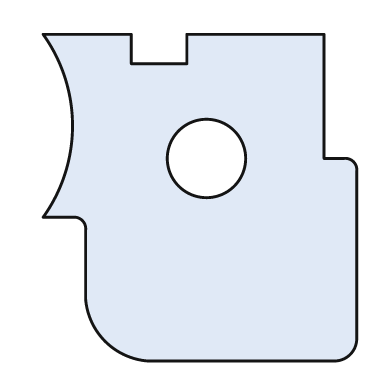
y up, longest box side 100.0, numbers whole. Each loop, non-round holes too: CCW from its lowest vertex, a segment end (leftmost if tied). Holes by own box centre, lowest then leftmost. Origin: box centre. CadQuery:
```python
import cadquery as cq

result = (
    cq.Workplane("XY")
    .moveTo(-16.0, -50.0)
    .lineTo(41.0, -50.0)
    .threePointArc((46.0, -48.0), (48.0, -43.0))
    .lineTo(48.0, 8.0)
    .threePointArc((47.0, 11.0), (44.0, 12.0))
    .lineTo(38.0, 12.0)
    .lineTo(38.0, 50.0)
    .lineTo(-4.0, 50.0)
    .lineTo(-4.0, 41.0)
    .lineTo(-21.0, 41.0)
    .lineTo(-21.0, 50.0)
    .lineTo(-48.0, 50.0)
    .threePointArc((-39.0, 22.0), (-48.0, -6.0))
    .lineTo(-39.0, -6.0)
    .threePointArc((-36.0, -7.0), (-35.0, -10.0))
    .lineTo(-35.0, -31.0)
    .threePointArc((-29.0, -44.0), (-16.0, -50.0))
    .close()
    .moveTo(2.0, 12.0)
    .circle(12.0)
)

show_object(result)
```